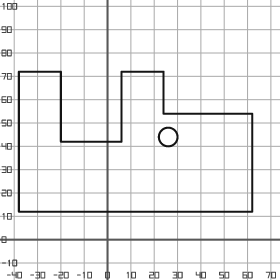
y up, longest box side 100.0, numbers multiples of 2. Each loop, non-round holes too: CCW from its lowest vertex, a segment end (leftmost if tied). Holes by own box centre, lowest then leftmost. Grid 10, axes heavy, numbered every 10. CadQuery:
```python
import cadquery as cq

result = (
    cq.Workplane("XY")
    .moveTo(-38.0, 12.0)
    .lineTo(62.0, 12.0)
    .lineTo(62.0, 54.0)
    .lineTo(24.0, 54.0)
    .lineTo(24.0, 72.0)
    .lineTo(6.0, 72.0)
    .lineTo(6.0, 42.0)
    .lineTo(-20.0, 42.0)
    .lineTo(-20.0, 72.0)
    .lineTo(-38.0, 72.0)
    .close()
    .moveTo(26.0, 44.0)
    .circle(4.0)
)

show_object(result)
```